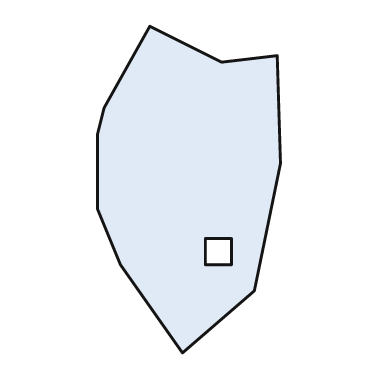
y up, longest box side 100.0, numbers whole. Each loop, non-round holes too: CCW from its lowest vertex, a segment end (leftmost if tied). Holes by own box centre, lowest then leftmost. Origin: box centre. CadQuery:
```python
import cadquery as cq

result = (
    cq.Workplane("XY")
    .moveTo(-2.0, -50.0)
    .lineTo(20.0, -31.0)
    .lineTo(28.0, 8.0)
    .lineTo(27.0, 41.0)
    .lineTo(10.0, 39.0)
    .lineTo(-12.0, 50.0)
    .lineTo(-26.0, 25.0)
    .lineTo(-28.0, 17.0)
    .lineTo(-28.0, -6.0)
    .lineTo(-21.0, -23.0)
    .close()
    .moveTo(5.0, -23.0)
    .lineTo(13.0, -23.0)
    .lineTo(13.0, -15.0)
    .lineTo(5.0, -15.0)
    .close()
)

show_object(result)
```